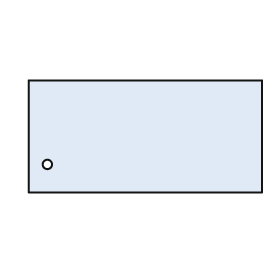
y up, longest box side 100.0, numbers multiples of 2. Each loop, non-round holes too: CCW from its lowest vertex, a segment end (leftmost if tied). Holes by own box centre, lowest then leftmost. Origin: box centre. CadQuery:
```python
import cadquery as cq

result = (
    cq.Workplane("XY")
    .moveTo(-50.0, -24.0)
    .lineTo(50.0, -24.0)
    .lineTo(50.0, 24.0)
    .lineTo(-50.0, 24.0)
    .close()
    .moveTo(-42.0, -12.0)
    .circle(2.0)
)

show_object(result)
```